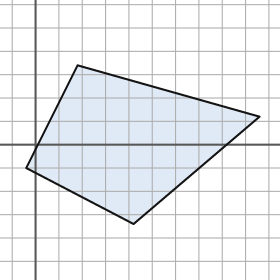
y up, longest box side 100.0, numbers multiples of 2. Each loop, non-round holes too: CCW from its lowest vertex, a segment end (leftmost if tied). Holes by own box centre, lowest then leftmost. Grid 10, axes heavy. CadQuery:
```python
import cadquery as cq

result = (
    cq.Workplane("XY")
    .moveTo(42.0, -34.0)
    .lineTo(96.0, 12.0)
    .lineTo(18.0, 34.0)
    .lineTo(-4.0, -10.0)
    .close()
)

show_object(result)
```